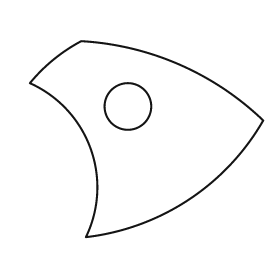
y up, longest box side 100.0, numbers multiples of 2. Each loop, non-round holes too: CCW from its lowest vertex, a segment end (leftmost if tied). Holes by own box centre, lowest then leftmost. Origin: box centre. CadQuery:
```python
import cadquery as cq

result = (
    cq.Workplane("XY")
    .moveTo(-26.0, -42.0)
    .threePointArc((18.0, -26.0), (50.0, 8.0))
    .threePointArc((14.0, 32.0), (-28.0, 42.0))
    .threePointArc((-40.0, 34.0), (-50.0, 24.0))
    .threePointArc((-24.0, -4.0), (-26.0, -42.0))
    .close()
    .moveTo(-8.0, 14.0)
    .circle(10.0)
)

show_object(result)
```